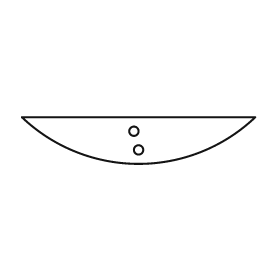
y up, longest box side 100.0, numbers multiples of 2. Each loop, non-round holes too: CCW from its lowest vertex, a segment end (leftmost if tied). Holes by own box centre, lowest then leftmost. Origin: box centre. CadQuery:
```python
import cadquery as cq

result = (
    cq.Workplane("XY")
    .moveTo(-50.0, 10.0)
    .threePointArc((0.0, -10.0), (50.0, 10.0))
    .close()
    .moveTo(0.0, -4.0)
    .circle(2.0)
    .moveTo(-2.0, 4.0)
    .circle(2.0)
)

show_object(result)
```